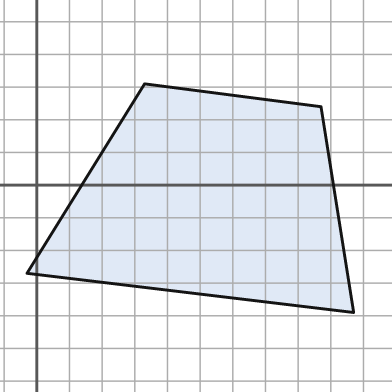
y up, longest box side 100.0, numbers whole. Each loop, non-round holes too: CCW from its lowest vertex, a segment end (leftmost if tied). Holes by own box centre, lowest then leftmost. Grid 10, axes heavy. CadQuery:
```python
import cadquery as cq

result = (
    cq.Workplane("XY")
    .moveTo(97.0, -39.0)
    .lineTo(87.0, 24.0)
    .lineTo(33.0, 31.0)
    .lineTo(-3.0, -27.0)
    .close()
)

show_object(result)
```